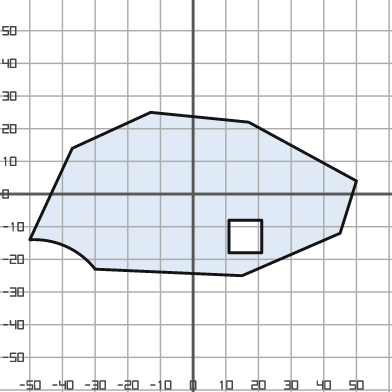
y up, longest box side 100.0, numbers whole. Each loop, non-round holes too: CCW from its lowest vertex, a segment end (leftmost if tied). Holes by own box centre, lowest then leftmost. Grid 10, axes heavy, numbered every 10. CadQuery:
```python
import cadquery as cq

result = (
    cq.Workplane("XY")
    .moveTo(15.0, -25.0)
    .lineTo(45.0, -12.0)
    .lineTo(50.0, 4.0)
    .lineTo(17.0, 22.0)
    .lineTo(-13.0, 25.0)
    .lineTo(-37.0, 14.0)
    .lineTo(-50.0, -14.0)
    .threePointArc((-39.0, -16.0), (-30.0, -23.0))
    .close()
    .moveTo(11.0, -18.0)
    .lineTo(21.0, -18.0)
    .lineTo(21.0, -8.0)
    .lineTo(11.0, -8.0)
    .close()
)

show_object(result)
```